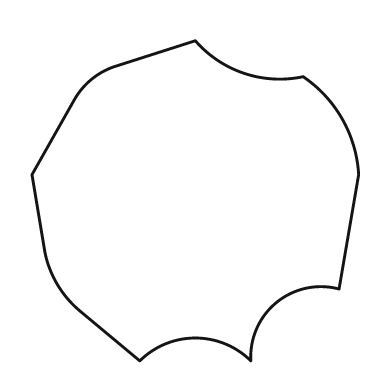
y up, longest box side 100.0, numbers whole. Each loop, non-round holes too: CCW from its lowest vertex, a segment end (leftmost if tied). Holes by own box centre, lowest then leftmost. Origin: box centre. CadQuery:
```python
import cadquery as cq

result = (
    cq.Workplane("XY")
    .moveTo(-17.0, -49.0)
    .threePointArc((0.0, -42.0), (17.0, -49.0))
    .threePointArc((25.0, -31.0), (44.0, -27.0))
    .lineTo(50.0, 8.0)
    .threePointArc((45.0, 25.0), (33.0, 38.0))
    .threePointArc((15.0, 39.0), (0.0, 49.0))
    .lineTo(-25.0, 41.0)
    .threePointArc((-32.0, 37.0), (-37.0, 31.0))
    .lineTo(-50.0, 8.0)
    .lineTo(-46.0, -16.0)
    .threePointArc((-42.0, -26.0), (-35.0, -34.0))
    .close()
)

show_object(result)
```